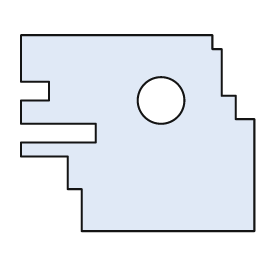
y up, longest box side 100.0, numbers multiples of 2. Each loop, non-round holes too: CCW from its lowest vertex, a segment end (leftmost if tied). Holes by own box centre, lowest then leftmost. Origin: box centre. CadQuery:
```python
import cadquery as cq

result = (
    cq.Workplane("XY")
    .moveTo(-24.0, -42.0)
    .lineTo(50.0, -42.0)
    .lineTo(50.0, 6.0)
    .lineTo(42.0, 6.0)
    .lineTo(42.0, 16.0)
    .lineTo(36.0, 16.0)
    .lineTo(36.0, 36.0)
    .lineTo(32.0, 36.0)
    .lineTo(32.0, 42.0)
    .lineTo(-50.0, 42.0)
    .lineTo(-50.0, 22.0)
    .lineTo(-38.0, 22.0)
    .lineTo(-38.0, 14.0)
    .lineTo(-50.0, 14.0)
    .lineTo(-50.0, 4.0)
    .lineTo(-18.0, 4.0)
    .lineTo(-18.0, -4.0)
    .lineTo(-50.0, -4.0)
    .lineTo(-50.0, -10.0)
    .lineTo(-30.0, -10.0)
    .lineTo(-30.0, -24.0)
    .lineTo(-24.0, -24.0)
    .close()
    .moveTo(10.0, 14.0)
    .circle(10.0)
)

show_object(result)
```